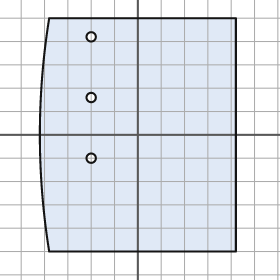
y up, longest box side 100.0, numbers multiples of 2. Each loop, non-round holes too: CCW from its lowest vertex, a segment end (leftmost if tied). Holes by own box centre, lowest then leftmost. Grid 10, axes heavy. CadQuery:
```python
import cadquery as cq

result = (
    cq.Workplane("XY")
    .moveTo(-38.0, -50.0)
    .lineTo(42.0, -50.0)
    .lineTo(42.0, 50.0)
    .lineTo(-38.0, 50.0)
    .threePointArc((-42.0, 0.0), (-38.0, -50.0))
    .close()
    .moveTo(-20.0, -10.0)
    .circle(2.0)
    .moveTo(-20.0, 16.0)
    .circle(2.0)
    .moveTo(-20.0, 42.0)
    .circle(2.0)
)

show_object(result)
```